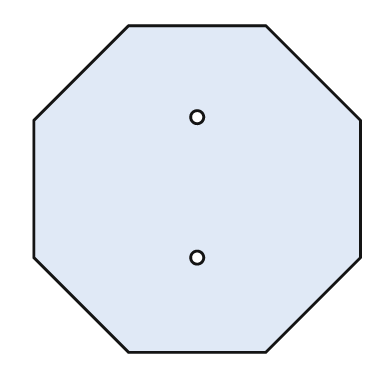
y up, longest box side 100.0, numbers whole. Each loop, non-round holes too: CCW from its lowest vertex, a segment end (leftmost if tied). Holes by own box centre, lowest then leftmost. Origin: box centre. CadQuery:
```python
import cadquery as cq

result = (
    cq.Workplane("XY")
    .moveTo(-21.0, -50.0)
    .lineTo(21.0, -50.0)
    .lineTo(50.0, -21.0)
    .lineTo(50.0, 21.0)
    .lineTo(21.0, 50.0)
    .lineTo(-21.0, 50.0)
    .lineTo(-50.0, 21.0)
    .lineTo(-50.0, -21.0)
    .close()
    .moveTo(0.0, -21.0)
    .circle(2.0)
    .moveTo(0.0, 22.0)
    .circle(2.0)
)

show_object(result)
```